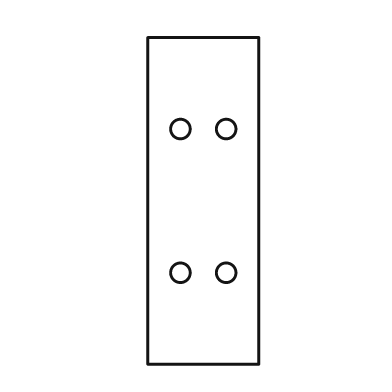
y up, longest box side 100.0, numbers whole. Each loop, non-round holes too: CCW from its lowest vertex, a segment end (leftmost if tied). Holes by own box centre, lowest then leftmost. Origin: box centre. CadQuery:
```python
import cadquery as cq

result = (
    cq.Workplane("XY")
    .moveTo(-17.0, -50.0)
    .lineTo(17.0, -50.0)
    .lineTo(17.0, 50.0)
    .lineTo(-17.0, 50.0)
    .close()
    .moveTo(-7.0, -22.0)
    .circle(3.0)
    .moveTo(7.0, -22.0)
    .circle(3.0)
    .moveTo(-7.0, 22.0)
    .circle(3.0)
    .moveTo(7.0, 22.0)
    .circle(3.0)
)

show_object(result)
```